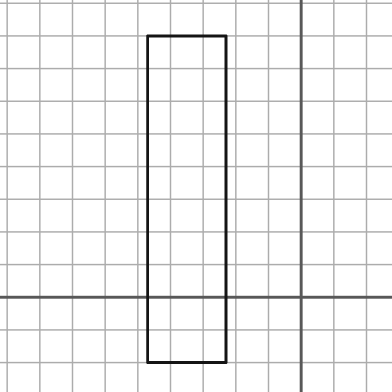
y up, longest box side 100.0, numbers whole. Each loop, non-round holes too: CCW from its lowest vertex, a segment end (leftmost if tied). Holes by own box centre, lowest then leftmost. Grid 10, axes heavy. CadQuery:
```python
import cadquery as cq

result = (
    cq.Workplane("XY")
    .moveTo(-47.0, -20.0)
    .lineTo(-23.0, -20.0)
    .lineTo(-23.0, 80.0)
    .lineTo(-47.0, 80.0)
    .close()
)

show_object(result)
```